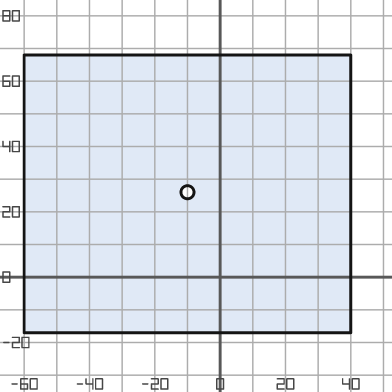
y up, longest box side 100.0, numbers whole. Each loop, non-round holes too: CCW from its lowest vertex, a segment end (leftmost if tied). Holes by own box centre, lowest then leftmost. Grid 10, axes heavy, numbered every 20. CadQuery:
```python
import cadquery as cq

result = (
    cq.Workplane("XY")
    .moveTo(-60.0, -17.0)
    .lineTo(40.0, -17.0)
    .lineTo(40.0, 68.0)
    .lineTo(-60.0, 68.0)
    .close()
    .moveTo(-10.0, 26.0)
    .circle(2.0)
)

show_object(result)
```